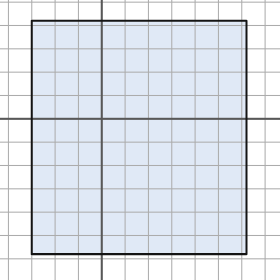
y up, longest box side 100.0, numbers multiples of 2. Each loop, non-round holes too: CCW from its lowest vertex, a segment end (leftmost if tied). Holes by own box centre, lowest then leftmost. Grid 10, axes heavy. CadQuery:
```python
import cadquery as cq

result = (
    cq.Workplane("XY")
    .moveTo(-30.0, -58.0)
    .lineTo(62.0, -58.0)
    .lineTo(62.0, 42.0)
    .lineTo(-30.0, 42.0)
    .close()
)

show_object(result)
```